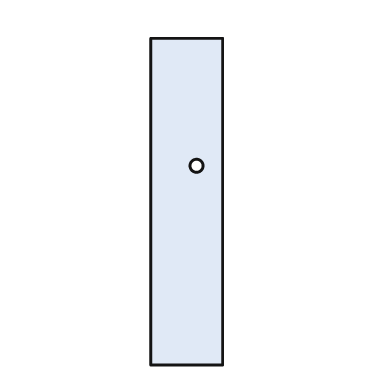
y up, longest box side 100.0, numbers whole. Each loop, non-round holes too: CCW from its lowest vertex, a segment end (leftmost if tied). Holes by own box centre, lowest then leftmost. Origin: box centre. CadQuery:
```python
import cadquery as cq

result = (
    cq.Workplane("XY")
    .moveTo(-11.0, -50.0)
    .lineTo(11.0, -50.0)
    .lineTo(11.0, 50.0)
    .lineTo(-11.0, 50.0)
    .close()
    .moveTo(3.0, 11.0)
    .circle(2.0)
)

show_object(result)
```